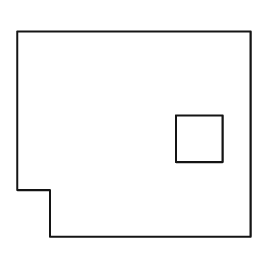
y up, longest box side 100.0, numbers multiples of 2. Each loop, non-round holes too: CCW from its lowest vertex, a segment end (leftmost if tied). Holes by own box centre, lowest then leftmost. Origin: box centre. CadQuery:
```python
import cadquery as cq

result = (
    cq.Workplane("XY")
    .moveTo(-36.0, -44.0)
    .lineTo(50.0, -44.0)
    .lineTo(50.0, 44.0)
    .lineTo(-50.0, 44.0)
    .lineTo(-50.0, -24.0)
    .lineTo(-36.0, -24.0)
    .close()
    .moveTo(18.0, -12.0)
    .lineTo(38.0, -12.0)
    .lineTo(38.0, 8.0)
    .lineTo(18.0, 8.0)
    .close()
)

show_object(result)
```